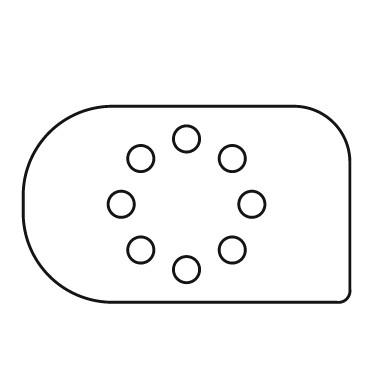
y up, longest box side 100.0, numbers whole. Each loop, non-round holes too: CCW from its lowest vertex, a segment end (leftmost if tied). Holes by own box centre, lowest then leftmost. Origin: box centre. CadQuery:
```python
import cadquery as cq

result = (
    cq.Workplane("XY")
    .moveTo(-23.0, -30.0)
    .lineTo(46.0, -30.0)
    .threePointArc((49.0, -29.0), (50.0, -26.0))
    .lineTo(50.0, 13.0)
    .threePointArc((45.0, 25.0), (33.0, 30.0))
    .lineTo(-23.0, 30.0)
    .threePointArc((-42.0, 22.0), (-50.0, 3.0))
    .lineTo(-50.0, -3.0)
    .threePointArc((-42.0, -22.0), (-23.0, -30.0))
    .close()
    .moveTo(0.0, -20.0)
    .circle(4.0)
    .moveTo(-14.0, -14.0)
    .circle(4.0)
    .moveTo(14.0, -14.0)
    .circle(4.0)
    .moveTo(-20.0, 0.0)
    .circle(4.0)
    .moveTo(20.0, 0.0)
    .circle(4.0)
    .moveTo(-14.0, 14.0)
    .circle(4.0)
    .moveTo(14.0, 14.0)
    .circle(4.0)
    .moveTo(0.0, 20.0)
    .circle(4.0)
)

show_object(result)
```